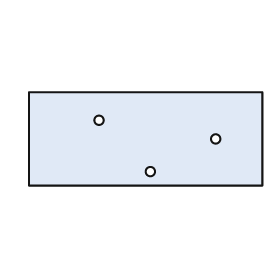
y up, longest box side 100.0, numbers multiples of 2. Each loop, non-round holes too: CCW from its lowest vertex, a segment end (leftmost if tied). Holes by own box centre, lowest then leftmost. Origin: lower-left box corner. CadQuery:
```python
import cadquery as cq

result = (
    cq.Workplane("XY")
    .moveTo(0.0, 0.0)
    .lineTo(100.0, 0.0)
    .lineTo(100.0, 40.0)
    .lineTo(0.0, 40.0)
    .close()
    .moveTo(52.0, 6.0)
    .circle(2.0)
    .moveTo(80.0, 20.0)
    .circle(2.0)
    .moveTo(30.0, 28.0)
    .circle(2.0)
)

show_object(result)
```